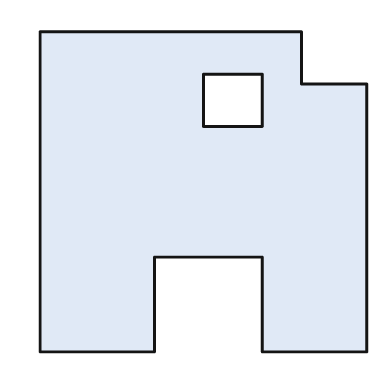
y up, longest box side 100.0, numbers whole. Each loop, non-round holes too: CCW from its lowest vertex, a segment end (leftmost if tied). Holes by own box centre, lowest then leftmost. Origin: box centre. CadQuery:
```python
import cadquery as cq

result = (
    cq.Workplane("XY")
    .moveTo(-50.0, -49.0)
    .lineTo(-15.0, -49.0)
    .lineTo(-15.0, -20.0)
    .lineTo(18.0, -20.0)
    .lineTo(18.0, -49.0)
    .lineTo(50.0, -49.0)
    .lineTo(50.0, 33.0)
    .lineTo(30.0, 33.0)
    .lineTo(30.0, 49.0)
    .lineTo(-50.0, 49.0)
    .close()
    .moveTo(0.0, 20.0)
    .lineTo(18.0, 20.0)
    .lineTo(18.0, 36.0)
    .lineTo(0.0, 36.0)
    .close()
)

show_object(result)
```